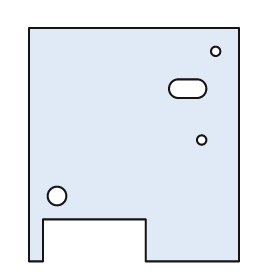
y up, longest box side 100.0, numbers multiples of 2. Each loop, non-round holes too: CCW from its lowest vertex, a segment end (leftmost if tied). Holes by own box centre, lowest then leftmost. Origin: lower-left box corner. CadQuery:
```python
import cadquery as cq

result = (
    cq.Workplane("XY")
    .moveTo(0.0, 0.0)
    .lineTo(6.0, 0.0)
    .lineTo(6.0, 18.0)
    .lineTo(50.0, 18.0)
    .lineTo(50.0, 0.0)
    .lineTo(90.0, 0.0)
    .lineTo(90.0, 100.0)
    .lineTo(0.0, 100.0)
    .close()
    .moveTo(12.0, 28.0)
    .circle(4.0)
    .moveTo(74.0, 52.0)
    .circle(2.0)
    .moveTo(64.0, 70.0)
    .lineTo(72.0, 70.0)
    .threePointArc((76.0, 74.0), (72.0, 78.0))
    .lineTo(64.0, 78.0)
    .threePointArc((60.0, 74.0), (64.0, 70.0))
    .close()
    .moveTo(80.0, 90.0)
    .circle(2.0)
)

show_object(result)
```